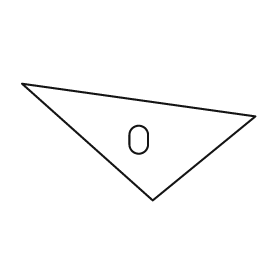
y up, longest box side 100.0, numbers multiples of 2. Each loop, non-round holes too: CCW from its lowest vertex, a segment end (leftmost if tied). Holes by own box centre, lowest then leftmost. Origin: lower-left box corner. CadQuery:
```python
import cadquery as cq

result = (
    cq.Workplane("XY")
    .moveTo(56.0, 0.0)
    .lineTo(100.0, 36.0)
    .lineTo(0.0, 50.0)
    .close()
    .moveTo(46.0, 24.0)
    .threePointArc((50.0, 20.0), (54.0, 24.0))
    .lineTo(54.0, 28.0)
    .threePointArc((50.0, 32.0), (46.0, 28.0))
    .close()
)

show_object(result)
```